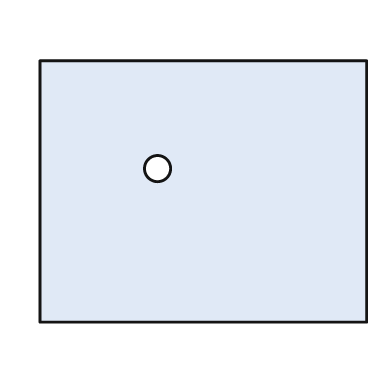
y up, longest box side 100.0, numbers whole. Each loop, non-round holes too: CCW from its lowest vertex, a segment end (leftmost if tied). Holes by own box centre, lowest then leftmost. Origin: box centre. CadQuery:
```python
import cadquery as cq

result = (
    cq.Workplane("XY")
    .moveTo(-50.0, -40.0)
    .lineTo(50.0, -40.0)
    .lineTo(50.0, 40.0)
    .lineTo(-50.0, 40.0)
    .close()
    .moveTo(-14.0, 7.0)
    .circle(4.0)
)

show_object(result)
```